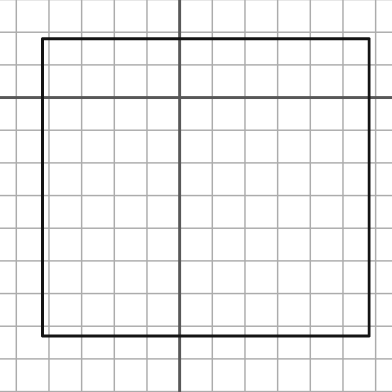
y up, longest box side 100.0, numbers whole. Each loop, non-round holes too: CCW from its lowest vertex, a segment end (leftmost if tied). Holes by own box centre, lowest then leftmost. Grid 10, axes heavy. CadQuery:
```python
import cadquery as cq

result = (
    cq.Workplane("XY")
    .moveTo(-42.0, -73.0)
    .lineTo(58.0, -73.0)
    .lineTo(58.0, 18.0)
    .lineTo(-42.0, 18.0)
    .close()
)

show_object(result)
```